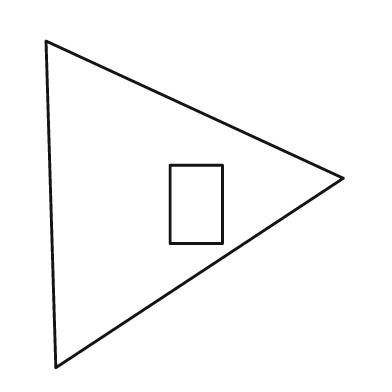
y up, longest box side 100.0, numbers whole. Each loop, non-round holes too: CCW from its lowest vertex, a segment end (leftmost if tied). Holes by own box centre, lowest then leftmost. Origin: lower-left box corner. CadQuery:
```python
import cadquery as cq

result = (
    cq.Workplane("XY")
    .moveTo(3.0, 0.0)
    .lineTo(91.0, 58.0)
    .lineTo(0.0, 100.0)
    .close()
    .moveTo(38.0, 38.0)
    .lineTo(54.0, 38.0)
    .lineTo(54.0, 62.0)
    .lineTo(38.0, 62.0)
    .close()
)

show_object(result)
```